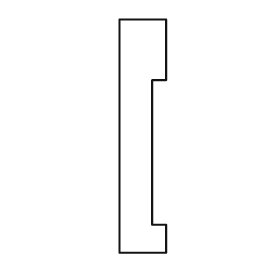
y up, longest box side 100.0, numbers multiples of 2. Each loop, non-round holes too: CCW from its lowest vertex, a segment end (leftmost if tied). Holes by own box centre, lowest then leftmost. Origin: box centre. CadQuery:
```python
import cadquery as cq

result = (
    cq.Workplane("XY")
    .moveTo(-10.0, -50.0)
    .lineTo(10.0, -50.0)
    .lineTo(10.0, -38.0)
    .lineTo(4.0, -38.0)
    .lineTo(4.0, 24.0)
    .lineTo(10.0, 24.0)
    .lineTo(10.0, 50.0)
    .lineTo(-10.0, 50.0)
    .close()
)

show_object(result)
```